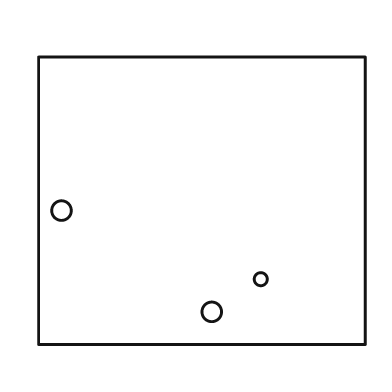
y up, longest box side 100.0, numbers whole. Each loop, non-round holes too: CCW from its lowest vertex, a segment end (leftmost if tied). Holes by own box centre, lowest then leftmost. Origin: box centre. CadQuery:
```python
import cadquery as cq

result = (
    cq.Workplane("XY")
    .moveTo(-50.0, -44.0)
    .lineTo(50.0, -44.0)
    .lineTo(50.0, 44.0)
    .lineTo(-50.0, 44.0)
    .close()
    .moveTo(3.0, -34.0)
    .circle(3.0)
    .moveTo(18.0, -24.0)
    .circle(2.0)
    .moveTo(-43.0, -3.0)
    .circle(3.0)
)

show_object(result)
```